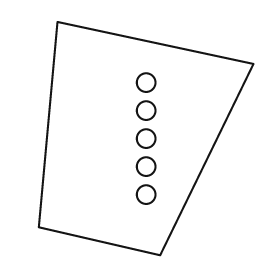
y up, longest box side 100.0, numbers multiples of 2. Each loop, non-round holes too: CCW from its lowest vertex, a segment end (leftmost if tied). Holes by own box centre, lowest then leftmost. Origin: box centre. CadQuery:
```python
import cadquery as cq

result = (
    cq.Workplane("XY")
    .moveTo(6.0, -50.0)
    .lineTo(46.0, 32.0)
    .lineTo(-38.0, 50.0)
    .lineTo(-46.0, -38.0)
    .close()
    .moveTo(0.0, -24.0)
    .circle(4.0)
    .moveTo(0.0, -12.0)
    .circle(4.0)
    .moveTo(0.0, 0.0)
    .circle(4.0)
    .moveTo(0.0, 12.0)
    .circle(4.0)
    .moveTo(0.0, 24.0)
    .circle(4.0)
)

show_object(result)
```